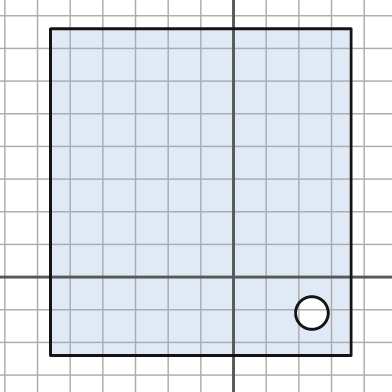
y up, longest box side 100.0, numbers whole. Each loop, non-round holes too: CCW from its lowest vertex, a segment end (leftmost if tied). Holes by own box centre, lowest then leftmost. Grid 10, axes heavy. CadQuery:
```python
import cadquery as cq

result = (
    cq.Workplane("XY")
    .moveTo(-56.0, -24.0)
    .lineTo(36.0, -24.0)
    .lineTo(36.0, 76.0)
    .lineTo(-56.0, 76.0)
    .close()
    .moveTo(24.0, -11.0)
    .circle(5.0)
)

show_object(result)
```